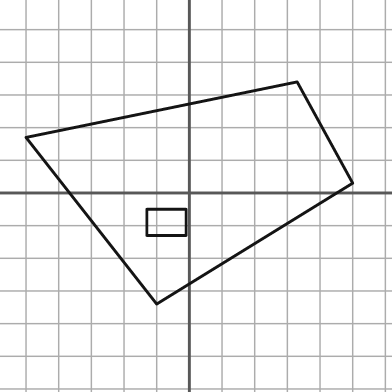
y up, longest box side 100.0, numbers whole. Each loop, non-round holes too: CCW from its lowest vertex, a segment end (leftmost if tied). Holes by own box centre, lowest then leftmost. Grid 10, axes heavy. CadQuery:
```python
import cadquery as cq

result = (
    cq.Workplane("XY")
    .moveTo(-10.0, -34.0)
    .lineTo(50.0, 3.0)
    .lineTo(33.0, 34.0)
    .lineTo(-50.0, 17.0)
    .close()
    .moveTo(-13.0, -13.0)
    .lineTo(-1.0, -13.0)
    .lineTo(-1.0, -5.0)
    .lineTo(-13.0, -5.0)
    .close()
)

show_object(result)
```